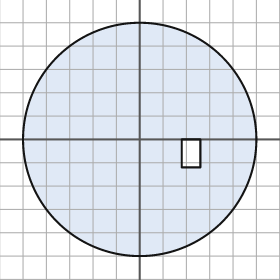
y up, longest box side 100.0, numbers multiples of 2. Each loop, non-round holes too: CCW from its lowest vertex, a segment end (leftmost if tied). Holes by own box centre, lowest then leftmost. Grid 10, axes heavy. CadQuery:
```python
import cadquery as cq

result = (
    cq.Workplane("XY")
    .moveTo(0.0, 0.0)
    .circle(50.0)
    .moveTo(18.0, -12.0)
    .lineTo(26.0, -12.0)
    .lineTo(26.0, 0.0)
    .lineTo(18.0, 0.0)
    .close()
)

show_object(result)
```